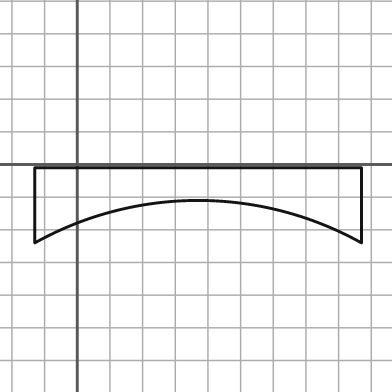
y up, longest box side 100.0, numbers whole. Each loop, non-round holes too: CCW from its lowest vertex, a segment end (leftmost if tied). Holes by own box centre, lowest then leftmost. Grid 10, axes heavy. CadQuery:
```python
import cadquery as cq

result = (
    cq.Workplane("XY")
    .moveTo(-13.0, -24.0)
    .threePointArc((37.0, -11.0), (87.0, -24.0))
    .lineTo(87.0, -1.0)
    .lineTo(-13.0, -1.0)
    .close()
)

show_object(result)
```